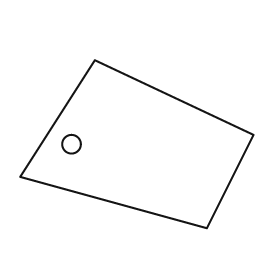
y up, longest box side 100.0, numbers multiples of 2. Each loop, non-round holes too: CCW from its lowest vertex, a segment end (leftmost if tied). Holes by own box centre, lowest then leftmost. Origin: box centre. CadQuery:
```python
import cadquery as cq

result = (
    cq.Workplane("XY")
    .moveTo(30.0, -36.0)
    .lineTo(50.0, 4.0)
    .lineTo(-18.0, 36.0)
    .lineTo(-50.0, -14.0)
    .close()
    .moveTo(-28.0, 0.0)
    .circle(4.0)
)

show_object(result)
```